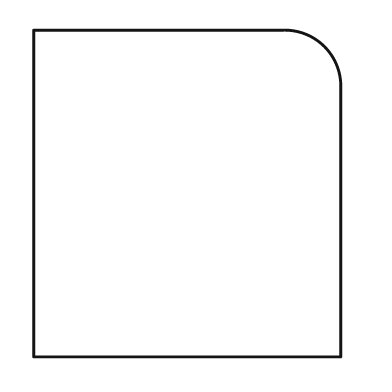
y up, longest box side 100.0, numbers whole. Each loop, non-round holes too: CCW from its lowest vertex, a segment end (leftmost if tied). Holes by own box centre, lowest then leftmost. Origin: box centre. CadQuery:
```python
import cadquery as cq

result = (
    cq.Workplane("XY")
    .moveTo(-47.0, -50.0)
    .lineTo(47.0, -50.0)
    .lineTo(47.0, 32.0)
    .threePointArc((42.0, 45.0), (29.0, 50.0))
    .lineTo(-47.0, 50.0)
    .close()
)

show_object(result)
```